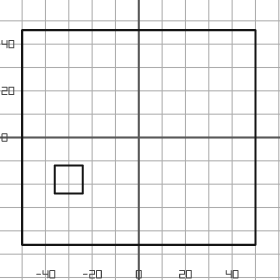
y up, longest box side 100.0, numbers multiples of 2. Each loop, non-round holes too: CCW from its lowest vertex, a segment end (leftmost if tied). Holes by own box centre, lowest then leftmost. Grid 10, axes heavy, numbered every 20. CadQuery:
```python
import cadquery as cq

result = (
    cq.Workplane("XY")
    .moveTo(-50.0, -46.0)
    .lineTo(50.0, -46.0)
    .lineTo(50.0, 46.0)
    .lineTo(-50.0, 46.0)
    .close()
    .moveTo(-36.0, -24.0)
    .lineTo(-24.0, -24.0)
    .lineTo(-24.0, -12.0)
    .lineTo(-36.0, -12.0)
    .close()
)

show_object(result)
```